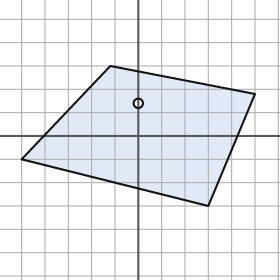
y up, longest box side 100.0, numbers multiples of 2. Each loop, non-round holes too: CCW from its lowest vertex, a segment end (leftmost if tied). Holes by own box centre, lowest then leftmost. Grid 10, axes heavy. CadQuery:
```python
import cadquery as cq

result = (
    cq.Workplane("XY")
    .moveTo(30.0, -30.0)
    .lineTo(50.0, 18.0)
    .lineTo(-12.0, 30.0)
    .lineTo(-50.0, -10.0)
    .close()
    .moveTo(0.0, 14.0)
    .circle(2.0)
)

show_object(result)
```